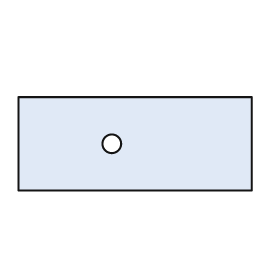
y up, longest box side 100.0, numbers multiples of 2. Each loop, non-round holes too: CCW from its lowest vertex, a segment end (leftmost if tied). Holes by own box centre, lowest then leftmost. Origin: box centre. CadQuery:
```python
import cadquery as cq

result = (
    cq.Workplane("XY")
    .moveTo(-50.0, -20.0)
    .lineTo(50.0, -20.0)
    .lineTo(50.0, 20.0)
    .lineTo(-50.0, 20.0)
    .close()
    .moveTo(-10.0, 0.0)
    .circle(4.0)
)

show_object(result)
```